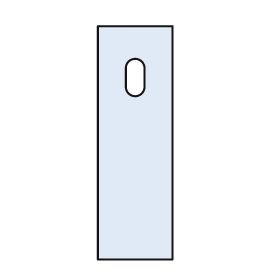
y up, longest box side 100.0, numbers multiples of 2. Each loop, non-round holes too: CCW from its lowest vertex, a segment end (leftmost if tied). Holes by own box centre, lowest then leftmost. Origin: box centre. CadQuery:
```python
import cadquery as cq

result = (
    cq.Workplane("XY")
    .moveTo(-16.0, -50.0)
    .lineTo(16.0, -50.0)
    .lineTo(16.0, 50.0)
    .lineTo(-16.0, 50.0)
    .close()
    .moveTo(-4.0, 24.0)
    .threePointArc((0.0, 20.0), (4.0, 24.0))
    .lineTo(4.0, 32.0)
    .threePointArc((0.0, 36.0), (-4.0, 32.0))
    .close()
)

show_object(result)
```